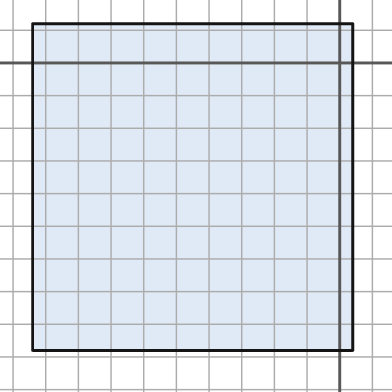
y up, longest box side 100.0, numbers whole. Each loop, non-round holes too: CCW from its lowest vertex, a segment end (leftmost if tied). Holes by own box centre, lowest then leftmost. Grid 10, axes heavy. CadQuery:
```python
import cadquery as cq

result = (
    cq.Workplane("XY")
    .moveTo(-94.0, -88.0)
    .lineTo(4.0, -88.0)
    .lineTo(4.0, 12.0)
    .lineTo(-94.0, 12.0)
    .close()
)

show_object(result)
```